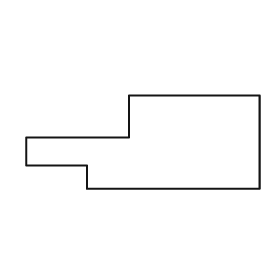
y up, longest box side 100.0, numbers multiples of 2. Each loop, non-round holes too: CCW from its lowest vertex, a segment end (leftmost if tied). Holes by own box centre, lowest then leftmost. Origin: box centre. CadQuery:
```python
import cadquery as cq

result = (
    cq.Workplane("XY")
    .moveTo(-24.0, -20.0)
    .lineTo(50.0, -20.0)
    .lineTo(50.0, 20.0)
    .lineTo(-6.0, 20.0)
    .lineTo(-6.0, 2.0)
    .lineTo(-50.0, 2.0)
    .lineTo(-50.0, -10.0)
    .lineTo(-24.0, -10.0)
    .close()
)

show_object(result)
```